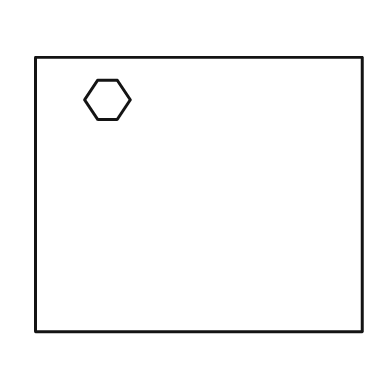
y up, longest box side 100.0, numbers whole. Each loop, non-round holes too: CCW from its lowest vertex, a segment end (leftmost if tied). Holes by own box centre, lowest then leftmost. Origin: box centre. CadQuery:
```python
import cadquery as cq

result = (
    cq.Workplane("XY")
    .moveTo(-50.0, -42.0)
    .lineTo(50.0, -42.0)
    .lineTo(50.0, 42.0)
    .lineTo(-50.0, 42.0)
    .close()
    .moveTo(-31.0, 23.0)
    .lineTo(-25.0, 23.0)
    .lineTo(-21.0, 29.0)
    .lineTo(-25.0, 35.0)
    .lineTo(-31.0, 35.0)
    .lineTo(-35.0, 29.0)
    .close()
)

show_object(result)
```